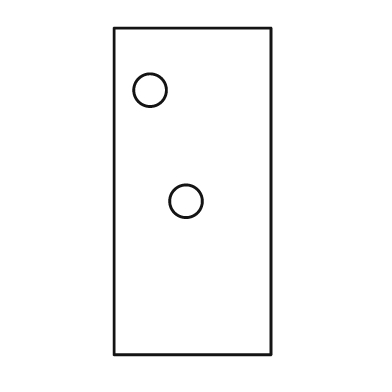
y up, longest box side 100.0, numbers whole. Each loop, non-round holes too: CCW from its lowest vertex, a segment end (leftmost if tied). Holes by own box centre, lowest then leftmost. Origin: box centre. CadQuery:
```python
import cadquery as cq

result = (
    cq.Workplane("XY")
    .moveTo(-24.0, -50.0)
    .lineTo(24.0, -50.0)
    .lineTo(24.0, 50.0)
    .lineTo(-24.0, 50.0)
    .close()
    .moveTo(-2.0, -3.0)
    .circle(5.0)
    .moveTo(-13.0, 31.0)
    .circle(5.0)
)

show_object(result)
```